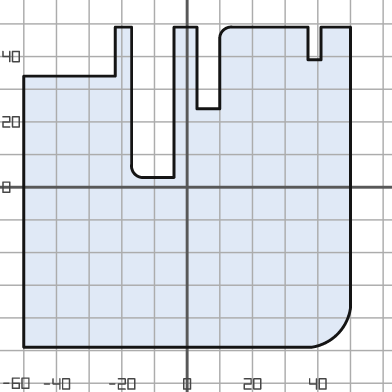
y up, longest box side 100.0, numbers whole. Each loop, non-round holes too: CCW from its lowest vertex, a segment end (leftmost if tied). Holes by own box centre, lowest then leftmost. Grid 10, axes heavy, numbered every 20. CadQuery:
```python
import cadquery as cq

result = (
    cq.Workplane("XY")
    .moveTo(-50.0, -49.0)
    .lineTo(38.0, -49.0)
    .threePointArc((46.0, -45.0), (50.0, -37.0))
    .lineTo(50.0, 49.0)
    .lineTo(41.0, 49.0)
    .lineTo(41.0, 39.0)
    .lineTo(37.0, 39.0)
    .lineTo(37.0, 49.0)
    .lineTo(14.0, 49.0)
    .threePointArc((11.0, 48.0), (10.0, 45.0))
    .lineTo(10.0, 24.0)
    .lineTo(3.0, 24.0)
    .lineTo(3.0, 49.0)
    .lineTo(-4.0, 49.0)
    .lineTo(-4.0, 3.0)
    .lineTo(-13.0, 3.0)
    .threePointArc((-16.0, 4.0), (-17.0, 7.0))
    .lineTo(-17.0, 49.0)
    .lineTo(-22.0, 49.0)
    .lineTo(-22.0, 34.0)
    .lineTo(-50.0, 34.0)
    .close()
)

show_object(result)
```